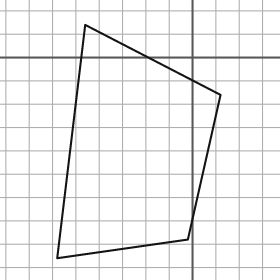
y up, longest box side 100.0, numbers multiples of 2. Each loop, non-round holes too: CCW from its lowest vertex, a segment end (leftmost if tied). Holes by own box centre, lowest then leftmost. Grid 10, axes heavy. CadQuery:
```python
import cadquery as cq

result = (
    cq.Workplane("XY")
    .moveTo(-58.0, -86.0)
    .lineTo(-2.0, -78.0)
    .lineTo(12.0, -16.0)
    .lineTo(-46.0, 14.0)
    .close()
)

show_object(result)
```